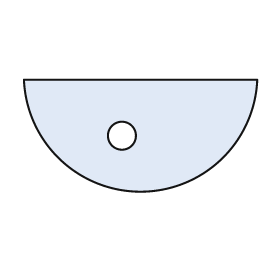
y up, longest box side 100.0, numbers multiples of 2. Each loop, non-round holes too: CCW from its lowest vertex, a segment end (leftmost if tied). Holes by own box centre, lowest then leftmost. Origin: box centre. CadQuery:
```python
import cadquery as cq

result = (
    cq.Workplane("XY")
    .moveTo(-50.0, 24.0)
    .threePointArc((0.0, -24.0), (50.0, 24.0))
    .close()
    .moveTo(-8.0, 0.0)
    .circle(6.0)
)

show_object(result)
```